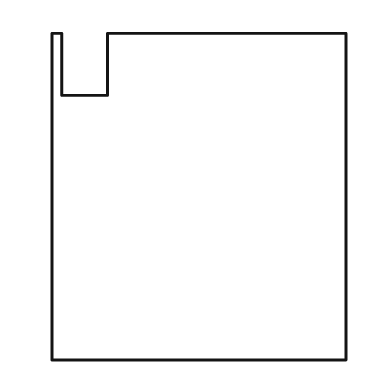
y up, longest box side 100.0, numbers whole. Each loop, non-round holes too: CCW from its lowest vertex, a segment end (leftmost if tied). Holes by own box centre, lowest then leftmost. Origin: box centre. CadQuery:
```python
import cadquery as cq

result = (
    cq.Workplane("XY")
    .moveTo(-45.0, -50.0)
    .lineTo(45.0, -50.0)
    .lineTo(45.0, 50.0)
    .lineTo(-28.0, 50.0)
    .lineTo(-28.0, 31.0)
    .lineTo(-42.0, 31.0)
    .lineTo(-42.0, 50.0)
    .lineTo(-45.0, 50.0)
    .close()
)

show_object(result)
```